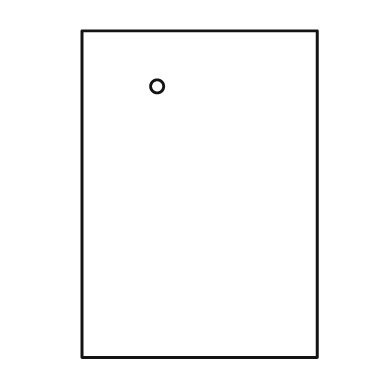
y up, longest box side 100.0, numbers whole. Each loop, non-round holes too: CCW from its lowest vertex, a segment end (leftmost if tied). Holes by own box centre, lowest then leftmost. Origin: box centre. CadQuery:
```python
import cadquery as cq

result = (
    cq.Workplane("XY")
    .moveTo(-36.0, -50.0)
    .lineTo(36.0, -50.0)
    .lineTo(36.0, 50.0)
    .lineTo(-36.0, 50.0)
    .close()
    .moveTo(-13.0, 33.0)
    .circle(2.0)
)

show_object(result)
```